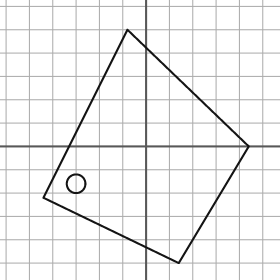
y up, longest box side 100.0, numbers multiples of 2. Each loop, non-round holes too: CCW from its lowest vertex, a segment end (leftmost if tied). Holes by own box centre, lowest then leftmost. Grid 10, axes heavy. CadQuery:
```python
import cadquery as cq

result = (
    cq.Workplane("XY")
    .moveTo(14.0, -50.0)
    .lineTo(44.0, 0.0)
    .lineTo(-8.0, 50.0)
    .lineTo(-44.0, -22.0)
    .close()
    .moveTo(-30.0, -16.0)
    .circle(4.0)
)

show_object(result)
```